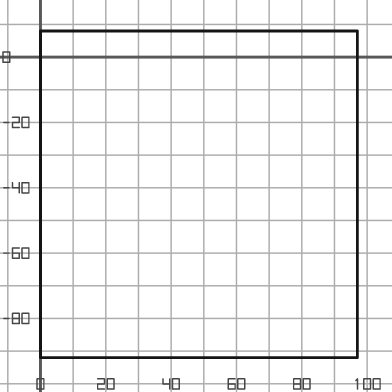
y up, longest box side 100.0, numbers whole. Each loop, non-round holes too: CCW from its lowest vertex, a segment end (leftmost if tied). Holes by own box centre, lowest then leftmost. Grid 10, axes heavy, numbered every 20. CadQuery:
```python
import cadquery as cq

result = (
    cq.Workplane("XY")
    .moveTo(0.0, -92.0)
    .lineTo(97.0, -92.0)
    .lineTo(97.0, 8.0)
    .lineTo(0.0, 8.0)
    .close()
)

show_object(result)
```